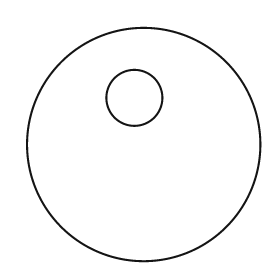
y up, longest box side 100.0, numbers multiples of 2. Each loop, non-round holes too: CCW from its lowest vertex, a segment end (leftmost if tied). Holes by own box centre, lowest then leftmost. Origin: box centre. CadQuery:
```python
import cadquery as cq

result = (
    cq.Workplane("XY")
    .moveTo(0.0, 0.0)
    .circle(50.0)
    .moveTo(-4.0, 20.0)
    .circle(12.0)
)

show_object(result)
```